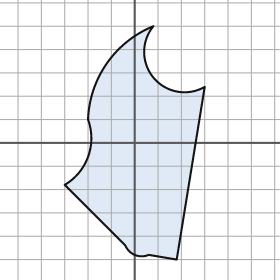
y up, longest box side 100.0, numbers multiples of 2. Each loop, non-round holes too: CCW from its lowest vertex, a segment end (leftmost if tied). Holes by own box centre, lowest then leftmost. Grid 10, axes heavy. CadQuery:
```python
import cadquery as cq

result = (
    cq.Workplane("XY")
    .moveTo(18.0, -50.0)
    .lineTo(30.0, 24.0)
    .threePointArc((8.0, 28.0), (8.0, 50.0))
    .threePointArc((-12.0, 34.0), (-20.0, 10.0))
    .threePointArc((-20.0, -6.0), (-30.0, -18.0))
    .lineTo(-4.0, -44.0)
    .threePointArc((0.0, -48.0), (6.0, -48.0))
    .close()
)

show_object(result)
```